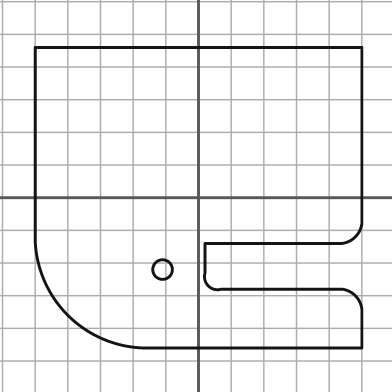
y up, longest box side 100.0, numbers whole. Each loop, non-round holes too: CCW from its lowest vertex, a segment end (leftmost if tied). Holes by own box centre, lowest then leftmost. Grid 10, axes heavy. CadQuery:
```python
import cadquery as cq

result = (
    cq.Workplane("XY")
    .moveTo(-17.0, -46.0)
    .lineTo(50.0, -46.0)
    .lineTo(50.0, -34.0)
    .threePointArc((48.0, -30.0), (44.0, -28.0))
    .lineTo(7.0, -28.0)
    .threePointArc((3.0, -27.0), (2.0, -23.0))
    .lineTo(2.0, -14.0)
    .lineTo(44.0, -14.0)
    .threePointArc((48.0, -12.0), (50.0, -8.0))
    .lineTo(50.0, 46.0)
    .lineTo(-50.0, 46.0)
    .lineTo(-50.0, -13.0)
    .threePointArc((-40.0, -36.0), (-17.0, -46.0))
    .close()
    .moveTo(-11.0, -22.0)
    .circle(3.0)
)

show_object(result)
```